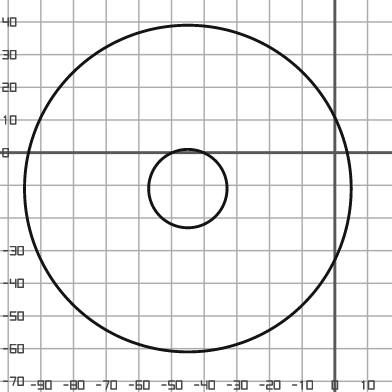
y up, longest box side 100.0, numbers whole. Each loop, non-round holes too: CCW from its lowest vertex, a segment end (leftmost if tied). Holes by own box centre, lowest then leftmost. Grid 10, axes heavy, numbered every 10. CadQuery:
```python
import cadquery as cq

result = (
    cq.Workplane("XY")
    .moveTo(-45.0, -11.0)
    .circle(50.0)
    .moveTo(-45.0, -11.0)
    .circle(12.0)
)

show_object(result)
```